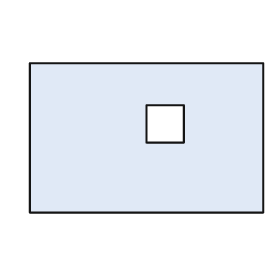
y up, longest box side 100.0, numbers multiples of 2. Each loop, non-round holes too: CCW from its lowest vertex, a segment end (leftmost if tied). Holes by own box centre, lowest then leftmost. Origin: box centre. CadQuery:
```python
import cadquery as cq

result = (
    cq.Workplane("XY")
    .moveTo(-50.0, -32.0)
    .lineTo(50.0, -32.0)
    .lineTo(50.0, 32.0)
    .lineTo(-50.0, 32.0)
    .close()
    .moveTo(0.0, -2.0)
    .lineTo(16.0, -2.0)
    .lineTo(16.0, 14.0)
    .lineTo(0.0, 14.0)
    .close()
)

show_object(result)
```